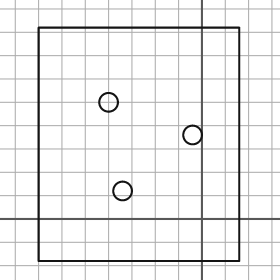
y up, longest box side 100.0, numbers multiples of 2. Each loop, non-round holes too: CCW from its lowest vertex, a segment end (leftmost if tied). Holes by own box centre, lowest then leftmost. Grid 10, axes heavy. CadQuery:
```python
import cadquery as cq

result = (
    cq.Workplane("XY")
    .moveTo(-70.0, -18.0)
    .lineTo(16.0, -18.0)
    .lineTo(16.0, 82.0)
    .lineTo(-70.0, 82.0)
    .close()
    .moveTo(-34.0, 12.0)
    .circle(4.0)
    .moveTo(-4.0, 36.0)
    .circle(4.0)
    .moveTo(-40.0, 50.0)
    .circle(4.0)
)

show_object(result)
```